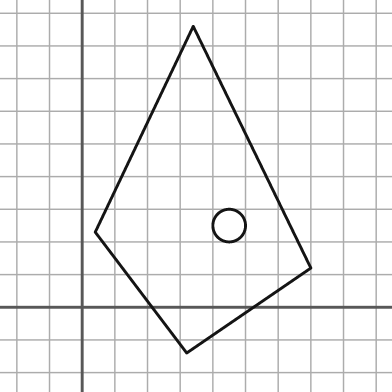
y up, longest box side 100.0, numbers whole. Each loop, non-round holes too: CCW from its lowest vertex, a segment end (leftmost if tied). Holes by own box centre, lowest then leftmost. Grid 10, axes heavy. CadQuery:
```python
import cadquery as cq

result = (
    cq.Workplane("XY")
    .moveTo(32.0, -14.0)
    .lineTo(70.0, 12.0)
    .lineTo(34.0, 86.0)
    .lineTo(4.0, 23.0)
    .close()
    .moveTo(45.0, 25.0)
    .circle(5.0)
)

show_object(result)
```